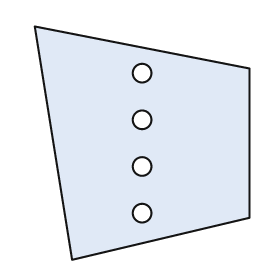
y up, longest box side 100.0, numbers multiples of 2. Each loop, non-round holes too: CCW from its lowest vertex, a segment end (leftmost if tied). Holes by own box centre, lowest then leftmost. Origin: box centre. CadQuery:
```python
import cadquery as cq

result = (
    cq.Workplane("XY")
    .moveTo(-30.0, -50.0)
    .lineTo(46.0, -32.0)
    .lineTo(46.0, 32.0)
    .lineTo(-46.0, 50.0)
    .close()
    .moveTo(0.0, -30.0)
    .circle(4.0)
    .moveTo(0.0, -10.0)
    .circle(4.0)
    .moveTo(0.0, 10.0)
    .circle(4.0)
    .moveTo(0.0, 30.0)
    .circle(4.0)
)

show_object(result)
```